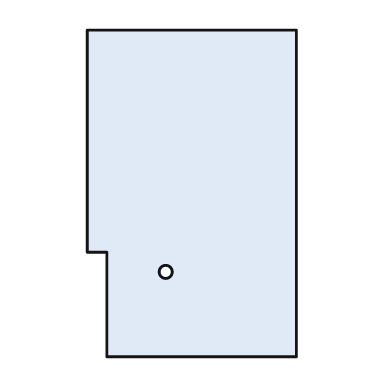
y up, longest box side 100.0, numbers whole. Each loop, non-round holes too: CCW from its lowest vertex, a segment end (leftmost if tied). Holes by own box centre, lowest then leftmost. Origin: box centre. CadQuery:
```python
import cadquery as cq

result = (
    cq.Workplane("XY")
    .moveTo(-26.0, -50.0)
    .lineTo(32.0, -50.0)
    .lineTo(32.0, 50.0)
    .lineTo(-32.0, 50.0)
    .lineTo(-32.0, -18.0)
    .lineTo(-26.0, -18.0)
    .close()
    .moveTo(-8.0, -24.0)
    .circle(2.0)
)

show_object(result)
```